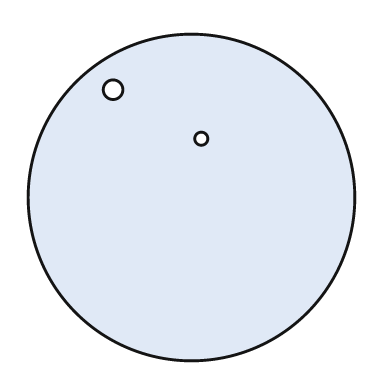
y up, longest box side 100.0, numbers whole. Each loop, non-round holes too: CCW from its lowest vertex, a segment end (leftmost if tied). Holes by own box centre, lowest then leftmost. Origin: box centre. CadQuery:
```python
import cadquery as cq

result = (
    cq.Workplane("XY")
    .moveTo(0.0, 0.0)
    .circle(50.0)
    .moveTo(3.0, 18.0)
    .circle(2.0)
    .moveTo(-24.0, 33.0)
    .circle(3.0)
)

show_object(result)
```